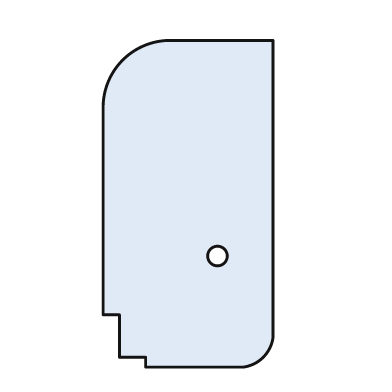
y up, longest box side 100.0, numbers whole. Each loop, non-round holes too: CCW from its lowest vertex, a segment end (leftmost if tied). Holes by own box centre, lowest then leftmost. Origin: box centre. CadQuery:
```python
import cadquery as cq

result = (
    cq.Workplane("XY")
    .moveTo(-13.0, -50.0)
    .lineTo(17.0, -50.0)
    .threePointArc((23.0, -47.0), (26.0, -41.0))
    .lineTo(26.0, 50.0)
    .lineTo(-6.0, 50.0)
    .threePointArc((-20.0, 44.0), (-26.0, 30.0))
    .lineTo(-26.0, -34.0)
    .lineTo(-21.0, -34.0)
    .lineTo(-21.0, -47.0)
    .lineTo(-13.0, -47.0)
    .close()
    .moveTo(9.0, -16.0)
    .circle(3.0)
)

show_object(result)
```